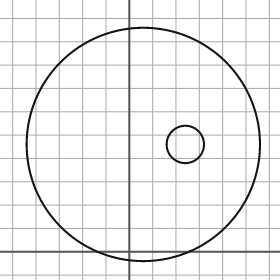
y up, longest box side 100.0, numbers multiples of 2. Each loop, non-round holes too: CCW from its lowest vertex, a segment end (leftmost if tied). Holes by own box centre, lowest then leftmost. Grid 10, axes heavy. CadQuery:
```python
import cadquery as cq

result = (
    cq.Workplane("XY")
    .moveTo(6.0, 46.0)
    .circle(50.0)
    .moveTo(24.0, 46.0)
    .circle(8.0)
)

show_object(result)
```